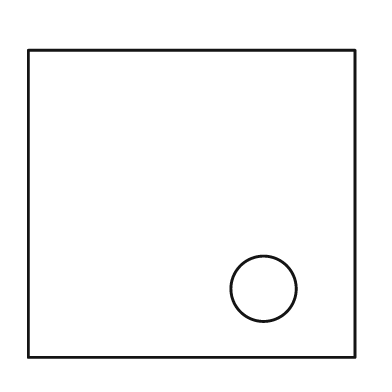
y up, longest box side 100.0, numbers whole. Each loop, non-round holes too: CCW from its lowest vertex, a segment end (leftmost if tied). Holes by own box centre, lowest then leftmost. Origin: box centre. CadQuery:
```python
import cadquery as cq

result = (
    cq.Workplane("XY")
    .moveTo(-50.0, -47.0)
    .lineTo(50.0, -47.0)
    .lineTo(50.0, 47.0)
    .lineTo(-50.0, 47.0)
    .close()
    .moveTo(22.0, -26.0)
    .circle(10.0)
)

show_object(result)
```